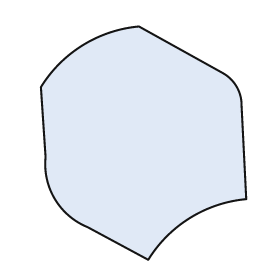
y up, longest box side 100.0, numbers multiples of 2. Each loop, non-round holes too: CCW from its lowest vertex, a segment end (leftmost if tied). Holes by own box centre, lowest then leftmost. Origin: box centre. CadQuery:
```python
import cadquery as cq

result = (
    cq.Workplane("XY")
    .moveTo(2.0, -50.0)
    .threePointArc((20.0, -32.0), (44.0, -24.0))
    .lineTo(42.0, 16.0)
    .threePointArc((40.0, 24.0), (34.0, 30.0))
    .lineTo(-2.0, 50.0)
    .threePointArc((-26.0, 42.0), (-44.0, 24.0))
    .lineTo(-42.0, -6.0)
    .threePointArc((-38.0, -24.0), (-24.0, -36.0))
    .close()
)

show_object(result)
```